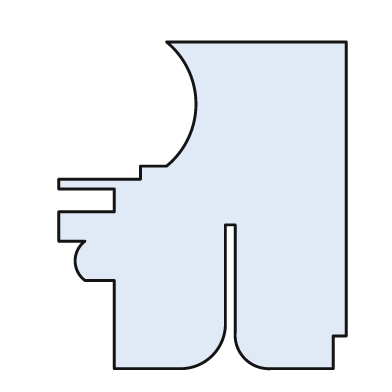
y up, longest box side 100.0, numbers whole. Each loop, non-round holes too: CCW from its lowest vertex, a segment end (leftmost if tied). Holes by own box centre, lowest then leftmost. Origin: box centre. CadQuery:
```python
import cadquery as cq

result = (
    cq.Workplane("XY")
    .moveTo(-27.0, -50.0)
    .lineTo(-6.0, -50.0)
    .threePointArc((3.0, -46.0), (7.0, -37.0))
    .lineTo(7.0, -6.0)
    .lineTo(10.0, -6.0)
    .lineTo(10.0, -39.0)
    .threePointArc((13.0, -47.0), (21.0, -50.0))
    .lineTo(40.0, -50.0)
    .lineTo(40.0, -40.0)
    .lineTo(44.0, -40.0)
    .lineTo(44.0, 50.0)
    .lineTo(-11.0, 50.0)
    .threePointArc((-2.0, 31.0), (-11.0, 12.0))
    .lineTo(-19.0, 12.0)
    .lineTo(-19.0, 8.0)
    .lineTo(-44.0, 8.0)
    .lineTo(-44.0, 5.0)
    .lineTo(-27.0, 5.0)
    .lineTo(-27.0, -2.0)
    .lineTo(-44.0, -2.0)
    .lineTo(-44.0, -11.0)
    .lineTo(-36.0, -11.0)
    .threePointArc((-39.0, -17.0), (-36.0, -23.0))
    .lineTo(-27.0, -23.0)
    .close()
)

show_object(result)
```